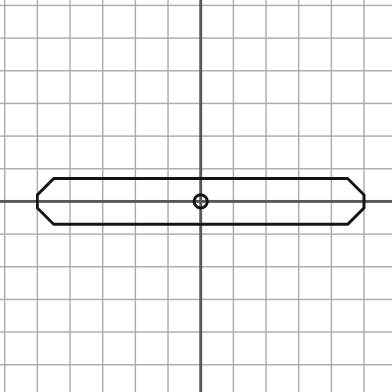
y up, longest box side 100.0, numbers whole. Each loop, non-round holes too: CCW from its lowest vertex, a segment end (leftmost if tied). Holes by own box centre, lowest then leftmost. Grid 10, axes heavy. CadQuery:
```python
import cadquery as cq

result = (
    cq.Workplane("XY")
    .moveTo(-45.0, -7.0)
    .lineTo(45.0, -7.0)
    .lineTo(50.0, -2.0)
    .lineTo(50.0, 2.0)
    .lineTo(45.0, 7.0)
    .lineTo(-45.0, 7.0)
    .lineTo(-50.0, 2.0)
    .lineTo(-50.0, -2.0)
    .close()
    .moveTo(0.0, 0.0)
    .circle(2.0)
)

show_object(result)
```